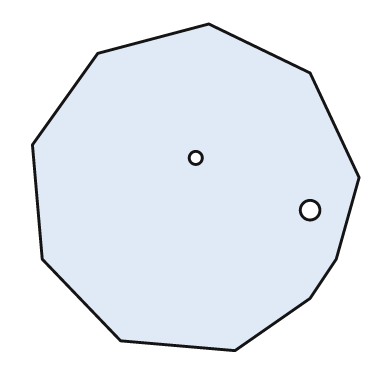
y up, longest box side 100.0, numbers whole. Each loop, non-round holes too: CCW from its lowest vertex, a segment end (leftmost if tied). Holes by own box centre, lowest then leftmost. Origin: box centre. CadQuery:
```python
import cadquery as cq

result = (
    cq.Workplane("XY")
    .moveTo(12.0, -50.0)
    .lineTo(35.0, -34.0)
    .lineTo(43.0, -22.0)
    .lineTo(50.0, 3.0)
    .lineTo(35.0, 35.0)
    .lineTo(4.0, 50.0)
    .lineTo(-30.0, 41.0)
    .lineTo(-50.0, 13.0)
    .lineTo(-47.0, -22.0)
    .lineTo(-23.0, -47.0)
    .close()
    .moveTo(35.0, -7.0)
    .circle(3.0)
    .moveTo(0.0, 9.0)
    .circle(2.0)
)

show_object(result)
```